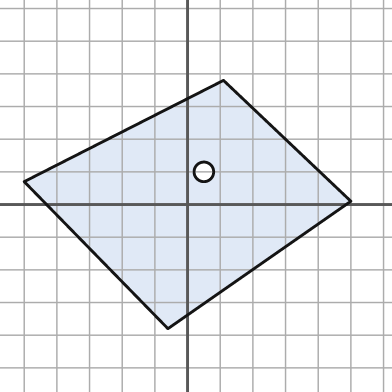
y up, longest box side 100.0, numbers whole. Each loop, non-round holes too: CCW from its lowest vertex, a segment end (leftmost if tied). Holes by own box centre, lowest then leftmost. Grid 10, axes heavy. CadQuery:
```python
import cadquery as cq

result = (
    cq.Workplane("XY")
    .moveTo(-6.0, -38.0)
    .lineTo(50.0, 1.0)
    .lineTo(11.0, 38.0)
    .lineTo(-50.0, 7.0)
    .close()
    .moveTo(5.0, 10.0)
    .circle(3.0)
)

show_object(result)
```